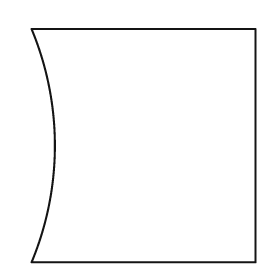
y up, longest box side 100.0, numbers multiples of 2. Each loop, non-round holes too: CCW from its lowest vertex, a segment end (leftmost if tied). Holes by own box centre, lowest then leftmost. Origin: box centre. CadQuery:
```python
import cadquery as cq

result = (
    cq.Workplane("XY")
    .moveTo(-48.0, -50.0)
    .lineTo(48.0, -50.0)
    .lineTo(48.0, 50.0)
    .lineTo(-48.0, 50.0)
    .threePointArc((-38.0, 0.0), (-48.0, -50.0))
    .close()
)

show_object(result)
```